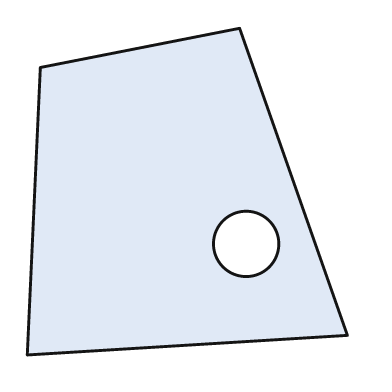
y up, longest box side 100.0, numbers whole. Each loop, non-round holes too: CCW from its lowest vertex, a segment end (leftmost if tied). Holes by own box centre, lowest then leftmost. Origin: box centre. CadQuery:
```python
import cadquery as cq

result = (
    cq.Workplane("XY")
    .moveTo(-49.0, -50.0)
    .lineTo(49.0, -44.0)
    .lineTo(16.0, 50.0)
    .lineTo(-45.0, 38.0)
    .close()
    .moveTo(18.0, -16.0)
    .circle(10.0)
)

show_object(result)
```